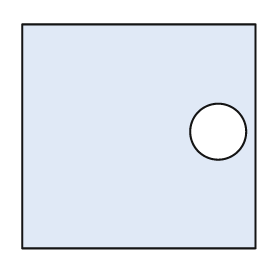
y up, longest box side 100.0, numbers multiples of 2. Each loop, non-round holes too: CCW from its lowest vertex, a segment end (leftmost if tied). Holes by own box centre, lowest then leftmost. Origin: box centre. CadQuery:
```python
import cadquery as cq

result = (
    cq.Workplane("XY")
    .moveTo(-50.0, -48.0)
    .lineTo(50.0, -48.0)
    .lineTo(50.0, 48.0)
    .lineTo(-50.0, 48.0)
    .close()
    .moveTo(34.0, 2.0)
    .circle(12.0)
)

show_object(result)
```